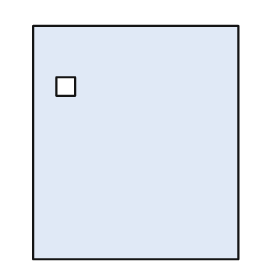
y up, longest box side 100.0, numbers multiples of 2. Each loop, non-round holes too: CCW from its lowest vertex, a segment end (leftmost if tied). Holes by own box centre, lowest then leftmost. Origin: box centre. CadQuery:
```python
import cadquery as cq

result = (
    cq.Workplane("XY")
    .moveTo(-44.0, -50.0)
    .lineTo(44.0, -50.0)
    .lineTo(44.0, 50.0)
    .lineTo(-44.0, 50.0)
    .close()
    .moveTo(-34.0, 20.0)
    .lineTo(-26.0, 20.0)
    .lineTo(-26.0, 28.0)
    .lineTo(-34.0, 28.0)
    .close()
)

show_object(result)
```